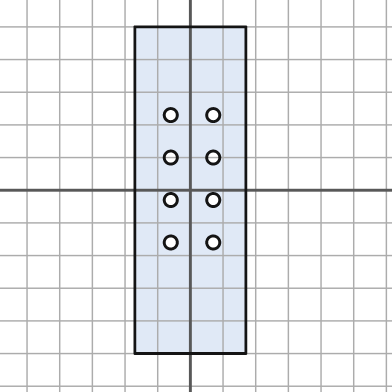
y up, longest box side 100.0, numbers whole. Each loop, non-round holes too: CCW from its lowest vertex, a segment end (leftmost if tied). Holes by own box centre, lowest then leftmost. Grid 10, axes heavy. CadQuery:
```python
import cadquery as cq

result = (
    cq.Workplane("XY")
    .moveTo(-17.0, -50.0)
    .lineTo(17.0, -50.0)
    .lineTo(17.0, 50.0)
    .lineTo(-17.0, 50.0)
    .close()
    .moveTo(-6.0, -16.0)
    .circle(2.0)
    .moveTo(7.0, -16.0)
    .circle(2.0)
    .moveTo(-6.0, -3.0)
    .circle(2.0)
    .moveTo(7.0, -3.0)
    .circle(2.0)
    .moveTo(-6.0, 10.0)
    .circle(2.0)
    .moveTo(7.0, 10.0)
    .circle(2.0)
    .moveTo(-6.0, 23.0)
    .circle(2.0)
    .moveTo(7.0, 23.0)
    .circle(2.0)
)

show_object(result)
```